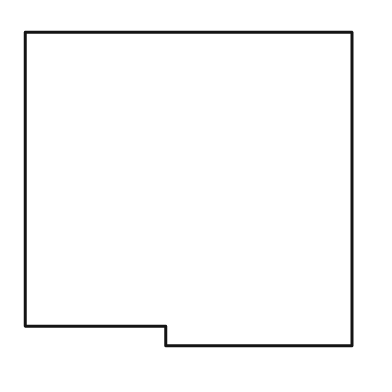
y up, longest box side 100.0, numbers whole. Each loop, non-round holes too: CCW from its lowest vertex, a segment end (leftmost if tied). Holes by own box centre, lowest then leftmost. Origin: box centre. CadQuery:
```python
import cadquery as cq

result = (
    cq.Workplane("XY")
    .moveTo(-7.0, -48.0)
    .lineTo(50.0, -48.0)
    .lineTo(50.0, 48.0)
    .lineTo(-50.0, 48.0)
    .lineTo(-50.0, -42.0)
    .lineTo(-7.0, -42.0)
    .close()
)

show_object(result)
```